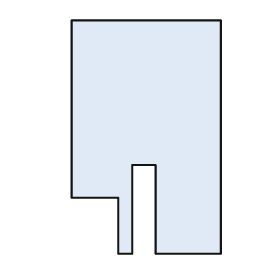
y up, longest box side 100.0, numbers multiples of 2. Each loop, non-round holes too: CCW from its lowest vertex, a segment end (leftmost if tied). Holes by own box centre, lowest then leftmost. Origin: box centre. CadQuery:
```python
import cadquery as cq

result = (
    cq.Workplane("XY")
    .moveTo(-12.0, -50.0)
    .lineTo(-6.0, -50.0)
    .lineTo(-6.0, -12.0)
    .lineTo(4.0, -12.0)
    .lineTo(4.0, -50.0)
    .lineTo(32.0, -50.0)
    .lineTo(32.0, 50.0)
    .lineTo(-32.0, 50.0)
    .lineTo(-32.0, -26.0)
    .lineTo(-12.0, -26.0)
    .close()
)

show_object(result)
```